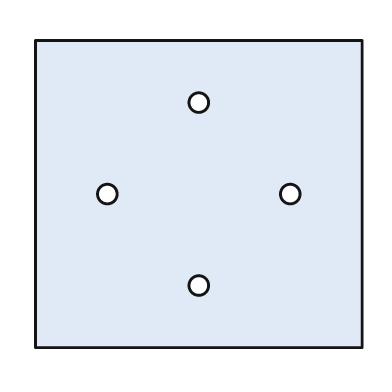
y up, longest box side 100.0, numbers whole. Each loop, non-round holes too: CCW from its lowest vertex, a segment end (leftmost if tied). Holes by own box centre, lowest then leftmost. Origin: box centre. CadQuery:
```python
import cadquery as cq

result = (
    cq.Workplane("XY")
    .moveTo(-50.0, -47.0)
    .lineTo(50.0, -47.0)
    .lineTo(50.0, 47.0)
    .lineTo(-50.0, 47.0)
    .close()
    .moveTo(0.0, -28.0)
    .circle(3.0)
    .moveTo(-28.0, 0.0)
    .circle(3.0)
    .moveTo(28.0, 0.0)
    .circle(3.0)
    .moveTo(0.0, 28.0)
    .circle(3.0)
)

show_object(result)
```